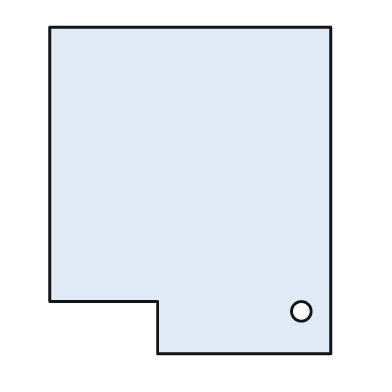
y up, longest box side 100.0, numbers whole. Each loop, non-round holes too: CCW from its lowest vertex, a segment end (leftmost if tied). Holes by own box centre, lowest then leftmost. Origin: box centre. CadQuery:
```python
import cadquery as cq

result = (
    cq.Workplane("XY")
    .moveTo(-10.0, -50.0)
    .lineTo(43.0, -50.0)
    .lineTo(43.0, 50.0)
    .lineTo(-43.0, 50.0)
    .lineTo(-43.0, -34.0)
    .lineTo(-10.0, -34.0)
    .close()
    .moveTo(34.0, -37.0)
    .circle(3.0)
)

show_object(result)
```